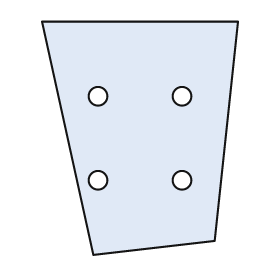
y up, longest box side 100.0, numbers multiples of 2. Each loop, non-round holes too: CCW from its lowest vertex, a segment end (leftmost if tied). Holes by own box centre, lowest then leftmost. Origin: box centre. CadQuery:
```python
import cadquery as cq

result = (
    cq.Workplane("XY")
    .moveTo(-20.0, -50.0)
    .lineTo(32.0, -44.0)
    .lineTo(42.0, 50.0)
    .lineTo(-42.0, 50.0)
    .close()
    .moveTo(-18.0, -18.0)
    .circle(4.0)
    .moveTo(18.0, -18.0)
    .circle(4.0)
    .moveTo(-18.0, 18.0)
    .circle(4.0)
    .moveTo(18.0, 18.0)
    .circle(4.0)
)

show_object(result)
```